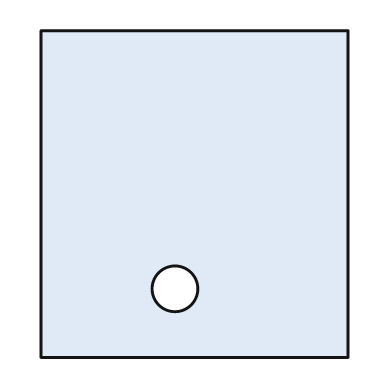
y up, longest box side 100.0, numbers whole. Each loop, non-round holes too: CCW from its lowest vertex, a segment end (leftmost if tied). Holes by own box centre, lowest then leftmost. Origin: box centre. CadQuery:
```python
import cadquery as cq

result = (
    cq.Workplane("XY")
    .moveTo(-47.0, -50.0)
    .lineTo(47.0, -50.0)
    .lineTo(47.0, 50.0)
    .lineTo(-47.0, 50.0)
    .close()
    .moveTo(-6.0, -29.0)
    .circle(7.0)
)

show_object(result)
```